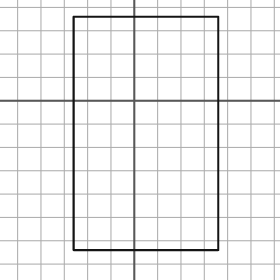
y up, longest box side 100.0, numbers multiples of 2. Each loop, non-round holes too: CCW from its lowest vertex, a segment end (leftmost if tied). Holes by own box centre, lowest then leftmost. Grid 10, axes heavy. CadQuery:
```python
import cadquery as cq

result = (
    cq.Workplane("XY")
    .moveTo(-26.0, -64.0)
    .lineTo(36.0, -64.0)
    .lineTo(36.0, 36.0)
    .lineTo(-26.0, 36.0)
    .close()
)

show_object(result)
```